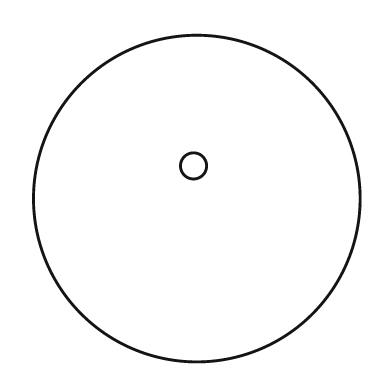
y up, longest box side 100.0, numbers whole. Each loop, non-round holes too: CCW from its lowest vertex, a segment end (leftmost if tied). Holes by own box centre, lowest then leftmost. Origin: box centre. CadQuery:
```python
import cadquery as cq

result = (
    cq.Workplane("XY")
    .moveTo(0.0, 0.0)
    .circle(50.0)
    .moveTo(-1.0, 10.0)
    .circle(4.0)
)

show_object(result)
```